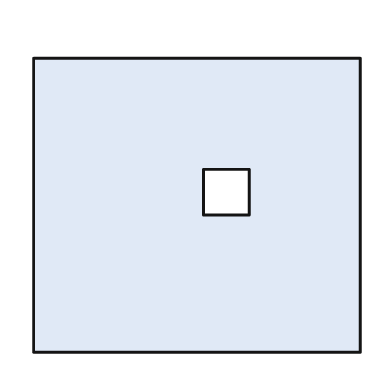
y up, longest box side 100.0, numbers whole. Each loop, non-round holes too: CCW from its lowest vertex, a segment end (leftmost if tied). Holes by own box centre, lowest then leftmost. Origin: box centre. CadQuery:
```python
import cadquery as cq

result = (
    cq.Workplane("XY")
    .moveTo(-50.0, -45.0)
    .lineTo(50.0, -45.0)
    .lineTo(50.0, 45.0)
    .lineTo(-50.0, 45.0)
    .close()
    .moveTo(2.0, -3.0)
    .lineTo(16.0, -3.0)
    .lineTo(16.0, 11.0)
    .lineTo(2.0, 11.0)
    .close()
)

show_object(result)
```